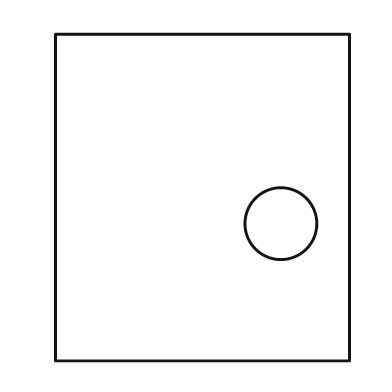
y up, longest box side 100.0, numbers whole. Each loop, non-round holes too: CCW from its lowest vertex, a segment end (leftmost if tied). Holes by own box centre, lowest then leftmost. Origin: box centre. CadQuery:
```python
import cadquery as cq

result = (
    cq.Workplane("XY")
    .moveTo(-45.0, -50.0)
    .lineTo(45.0, -50.0)
    .lineTo(45.0, 50.0)
    .lineTo(-45.0, 50.0)
    .close()
    .moveTo(24.0, -8.0)
    .circle(11.0)
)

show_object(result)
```